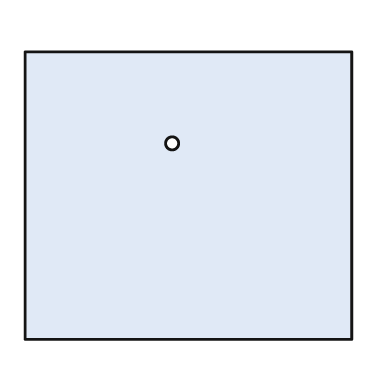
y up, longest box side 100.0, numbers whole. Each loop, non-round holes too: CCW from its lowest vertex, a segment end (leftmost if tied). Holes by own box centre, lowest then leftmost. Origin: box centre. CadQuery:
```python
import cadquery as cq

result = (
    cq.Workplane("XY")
    .moveTo(-50.0, -44.0)
    .lineTo(50.0, -44.0)
    .lineTo(50.0, 44.0)
    .lineTo(-50.0, 44.0)
    .close()
    .moveTo(-5.0, 16.0)
    .circle(2.0)
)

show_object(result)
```